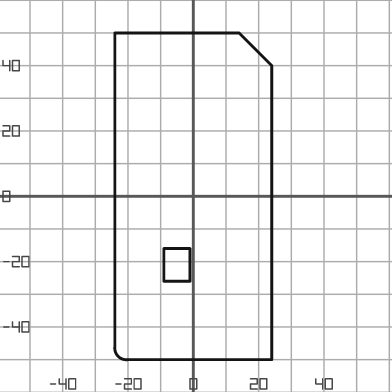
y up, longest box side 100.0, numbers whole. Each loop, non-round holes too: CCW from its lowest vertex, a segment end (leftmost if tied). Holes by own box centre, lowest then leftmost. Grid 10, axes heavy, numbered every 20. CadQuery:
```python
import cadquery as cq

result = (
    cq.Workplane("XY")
    .moveTo(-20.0, -50.0)
    .lineTo(24.0, -50.0)
    .lineTo(24.0, 40.0)
    .lineTo(14.0, 50.0)
    .lineTo(-24.0, 50.0)
    .lineTo(-24.0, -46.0)
    .threePointArc((-23.0, -49.0), (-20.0, -50.0))
    .close()
    .moveTo(-9.0, -26.0)
    .lineTo(-1.0, -26.0)
    .lineTo(-1.0, -16.0)
    .lineTo(-9.0, -16.0)
    .close()
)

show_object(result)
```